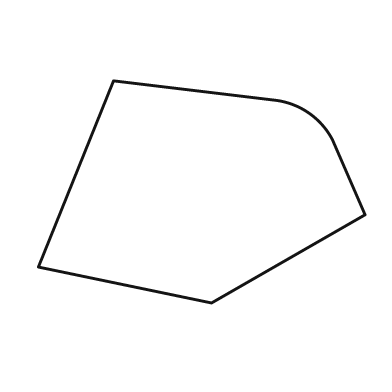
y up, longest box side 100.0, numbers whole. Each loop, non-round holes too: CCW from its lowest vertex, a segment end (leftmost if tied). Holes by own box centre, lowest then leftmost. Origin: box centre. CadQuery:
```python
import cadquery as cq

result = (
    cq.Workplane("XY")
    .moveTo(3.0, -34.0)
    .lineTo(50.0, -7.0)
    .lineTo(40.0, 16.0)
    .threePointArc((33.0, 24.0), (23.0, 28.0))
    .lineTo(-27.0, 34.0)
    .lineTo(-50.0, -23.0)
    .close()
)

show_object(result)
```